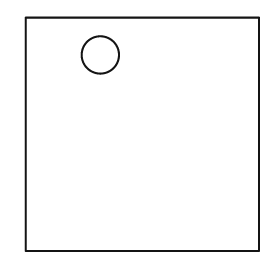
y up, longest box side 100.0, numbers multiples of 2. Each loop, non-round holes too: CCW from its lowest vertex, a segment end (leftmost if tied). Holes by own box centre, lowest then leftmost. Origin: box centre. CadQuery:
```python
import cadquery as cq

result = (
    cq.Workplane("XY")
    .moveTo(-50.0, -50.0)
    .lineTo(50.0, -50.0)
    .lineTo(50.0, 50.0)
    .lineTo(-50.0, 50.0)
    .close()
    .moveTo(-18.0, 34.0)
    .circle(8.0)
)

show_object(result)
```